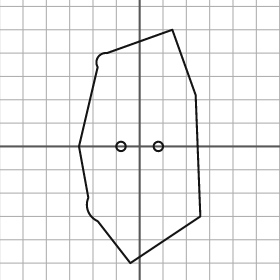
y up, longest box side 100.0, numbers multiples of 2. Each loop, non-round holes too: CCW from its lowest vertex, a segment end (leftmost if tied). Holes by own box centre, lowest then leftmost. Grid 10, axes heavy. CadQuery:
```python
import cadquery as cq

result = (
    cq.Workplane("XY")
    .moveTo(-4.0, -50.0)
    .lineTo(26.0, -30.0)
    .lineTo(24.0, 22.0)
    .lineTo(14.0, 50.0)
    .lineTo(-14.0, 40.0)
    .threePointArc((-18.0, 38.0), (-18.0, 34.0))
    .lineTo(-26.0, 0.0)
    .lineTo(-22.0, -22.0)
    .threePointArc((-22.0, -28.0), (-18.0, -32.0))
    .close()
    .moveTo(-8.0, 0.0)
    .circle(2.0)
    .moveTo(8.0, 0.0)
    .circle(2.0)
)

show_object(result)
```